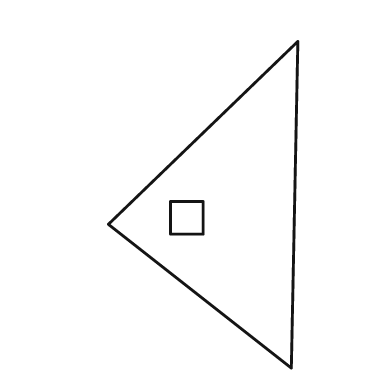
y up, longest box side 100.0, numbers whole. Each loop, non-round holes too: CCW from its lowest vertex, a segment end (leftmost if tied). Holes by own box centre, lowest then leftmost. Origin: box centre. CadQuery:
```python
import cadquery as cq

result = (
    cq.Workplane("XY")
    .moveTo(27.0, -50.0)
    .lineTo(29.0, 50.0)
    .lineTo(-29.0, -6.0)
    .close()
    .moveTo(-10.0, -9.0)
    .lineTo(0.0, -9.0)
    .lineTo(0.0, 1.0)
    .lineTo(-10.0, 1.0)
    .close()
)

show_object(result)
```